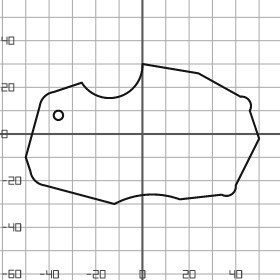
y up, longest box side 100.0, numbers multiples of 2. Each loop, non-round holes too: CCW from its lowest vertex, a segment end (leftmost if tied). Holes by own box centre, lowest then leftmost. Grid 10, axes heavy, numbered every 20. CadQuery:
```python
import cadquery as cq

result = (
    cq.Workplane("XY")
    .moveTo(-12.0, -30.0)
    .threePointArc((2.0, -26.0), (16.0, -28.0))
    .lineTo(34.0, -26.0)
    .threePointArc((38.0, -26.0), (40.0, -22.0))
    .lineTo(50.0, -2.0)
    .lineTo(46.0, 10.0)
    .threePointArc((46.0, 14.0), (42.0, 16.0))
    .lineTo(24.0, 26.0)
    .lineTo(0.0, 30.0)
    .threePointArc((-10.0, 16.0), (-26.0, 22.0))
    .lineTo(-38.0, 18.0)
    .threePointArc((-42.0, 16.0), (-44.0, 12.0))
    .lineTo(-50.0, -10.0)
    .lineTo(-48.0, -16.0)
    .threePointArc((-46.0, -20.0), (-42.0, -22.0))
    .close()
    .moveTo(-36.0, 8.0)
    .circle(2.0)
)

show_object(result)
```